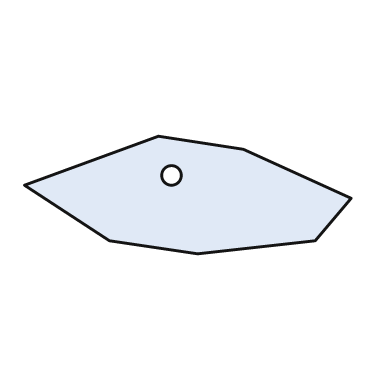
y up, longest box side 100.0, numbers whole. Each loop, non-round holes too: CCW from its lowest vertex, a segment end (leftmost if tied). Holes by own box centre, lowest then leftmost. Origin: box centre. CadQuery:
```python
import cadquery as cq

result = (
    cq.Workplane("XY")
    .moveTo(3.0, -18.0)
    .lineTo(39.0, -14.0)
    .lineTo(50.0, -1.0)
    .lineTo(17.0, 14.0)
    .lineTo(-9.0, 18.0)
    .lineTo(-50.0, 3.0)
    .lineTo(-24.0, -14.0)
    .close()
    .moveTo(-5.0, 6.0)
    .circle(3.0)
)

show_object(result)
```